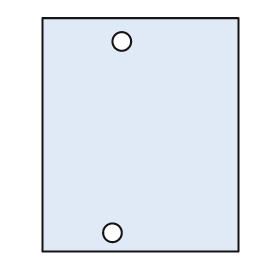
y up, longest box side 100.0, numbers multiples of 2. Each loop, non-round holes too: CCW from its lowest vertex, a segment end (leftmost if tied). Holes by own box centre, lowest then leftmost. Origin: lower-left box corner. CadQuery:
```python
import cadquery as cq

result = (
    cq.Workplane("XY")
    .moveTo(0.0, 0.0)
    .lineTo(84.0, 0.0)
    .lineTo(84.0, 100.0)
    .lineTo(0.0, 100.0)
    .close()
    .moveTo(30.0, 8.0)
    .circle(4.0)
    .moveTo(34.0, 90.0)
    .circle(4.0)
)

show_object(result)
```